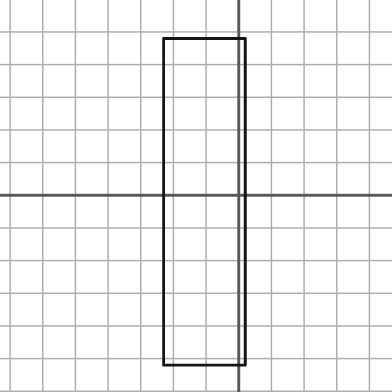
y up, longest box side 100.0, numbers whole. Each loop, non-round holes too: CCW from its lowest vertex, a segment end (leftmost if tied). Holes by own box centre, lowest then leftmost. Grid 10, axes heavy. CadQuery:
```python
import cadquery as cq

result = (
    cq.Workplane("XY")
    .moveTo(-23.0, -52.0)
    .lineTo(2.0, -52.0)
    .lineTo(2.0, 48.0)
    .lineTo(-23.0, 48.0)
    .close()
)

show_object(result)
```